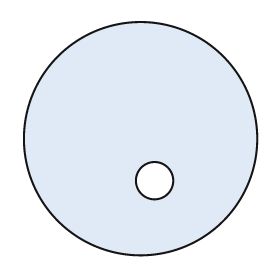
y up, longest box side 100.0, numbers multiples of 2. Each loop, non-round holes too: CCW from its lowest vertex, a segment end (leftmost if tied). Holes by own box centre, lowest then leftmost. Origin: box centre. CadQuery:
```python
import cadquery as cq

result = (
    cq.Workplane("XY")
    .moveTo(0.0, 0.0)
    .circle(50.0)
    .moveTo(6.0, -18.0)
    .circle(8.0)
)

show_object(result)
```